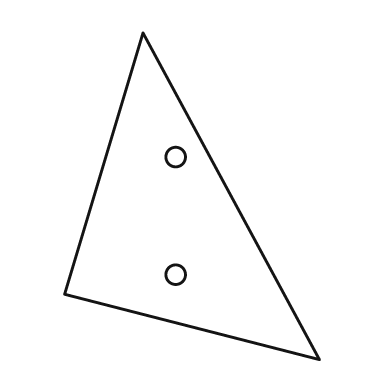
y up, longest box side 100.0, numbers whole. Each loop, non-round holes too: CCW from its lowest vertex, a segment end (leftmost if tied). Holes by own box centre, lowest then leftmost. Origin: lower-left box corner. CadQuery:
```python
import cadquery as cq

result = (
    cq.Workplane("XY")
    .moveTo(78.0, 0.0)
    .lineTo(24.0, 100.0)
    .lineTo(0.0, 20.0)
    .close()
    .moveTo(34.0, 26.0)
    .circle(3.0)
    .moveTo(34.0, 62.0)
    .circle(3.0)
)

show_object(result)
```